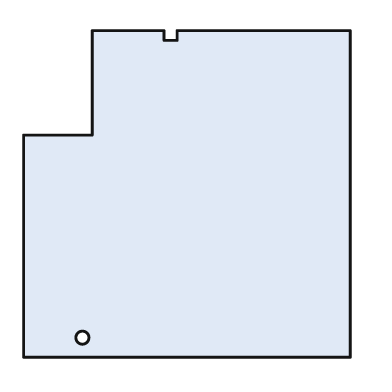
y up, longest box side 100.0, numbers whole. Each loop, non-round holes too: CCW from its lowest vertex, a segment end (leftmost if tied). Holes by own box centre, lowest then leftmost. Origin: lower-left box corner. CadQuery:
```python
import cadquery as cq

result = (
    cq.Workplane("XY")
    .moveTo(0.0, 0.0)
    .lineTo(100.0, 0.0)
    .lineTo(100.0, 100.0)
    .lineTo(47.0, 100.0)
    .lineTo(47.0, 97.0)
    .lineTo(43.0, 97.0)
    .lineTo(43.0, 100.0)
    .lineTo(21.0, 100.0)
    .lineTo(21.0, 68.0)
    .lineTo(0.0, 68.0)
    .close()
    .moveTo(18.0, 6.0)
    .circle(2.0)
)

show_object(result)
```